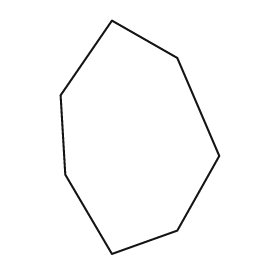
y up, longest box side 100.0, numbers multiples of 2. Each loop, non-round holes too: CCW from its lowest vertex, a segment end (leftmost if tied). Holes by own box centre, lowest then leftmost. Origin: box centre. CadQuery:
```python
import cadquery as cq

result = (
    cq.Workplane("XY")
    .moveTo(-12.0, -50.0)
    .lineTo(16.0, -40.0)
    .lineTo(34.0, -8.0)
    .lineTo(16.0, 34.0)
    .lineTo(-12.0, 50.0)
    .lineTo(-34.0, 18.0)
    .lineTo(-32.0, -16.0)
    .close()
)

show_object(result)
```